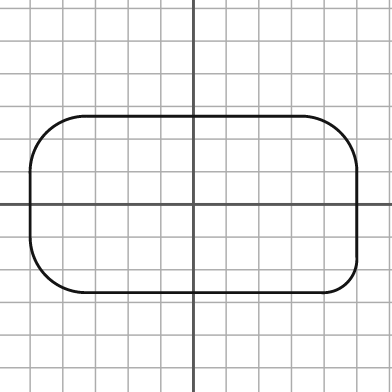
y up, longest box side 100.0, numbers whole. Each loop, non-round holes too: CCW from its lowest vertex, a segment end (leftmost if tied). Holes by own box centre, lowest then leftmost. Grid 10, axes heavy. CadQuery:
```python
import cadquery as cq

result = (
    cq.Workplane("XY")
    .moveTo(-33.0, -27.0)
    .lineTo(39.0, -27.0)
    .threePointArc((47.0, -24.0), (50.0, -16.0))
    .lineTo(50.0, 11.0)
    .threePointArc((45.0, 22.0), (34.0, 27.0))
    .lineTo(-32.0, 27.0)
    .threePointArc((-45.0, 22.0), (-50.0, 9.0))
    .lineTo(-50.0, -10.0)
    .threePointArc((-45.0, -22.0), (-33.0, -27.0))
    .close()
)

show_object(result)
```